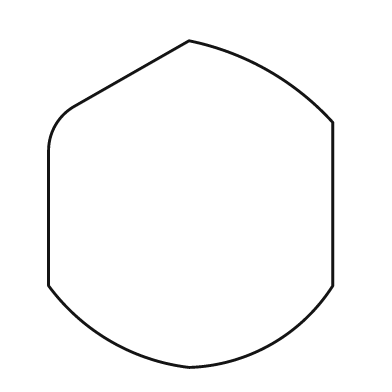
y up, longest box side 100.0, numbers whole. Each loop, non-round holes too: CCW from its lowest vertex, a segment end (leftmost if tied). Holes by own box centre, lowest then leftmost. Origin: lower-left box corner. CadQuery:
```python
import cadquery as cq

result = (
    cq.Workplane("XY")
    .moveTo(43.0, 0.0)
    .threePointArc((68.0, 7.0), (87.0, 25.0))
    .lineTo(87.0, 75.0)
    .threePointArc((67.0, 91.0), (43.0, 100.0))
    .lineTo(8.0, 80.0)
    .threePointArc((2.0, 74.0), (0.0, 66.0))
    .lineTo(0.0, 25.0)
    .threePointArc((19.0, 8.0), (43.0, 0.0))
    .close()
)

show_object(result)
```